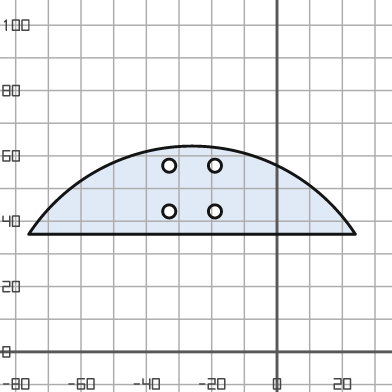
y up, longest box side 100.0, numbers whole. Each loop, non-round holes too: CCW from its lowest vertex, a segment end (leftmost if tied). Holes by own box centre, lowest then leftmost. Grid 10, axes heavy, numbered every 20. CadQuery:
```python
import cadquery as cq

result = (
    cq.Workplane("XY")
    .moveTo(-76.0, 36.0)
    .lineTo(24.0, 36.0)
    .threePointArc((-26.0, 63.0), (-76.0, 36.0))
    .close()
    .moveTo(-33.0, 43.0)
    .circle(2.0)
    .moveTo(-19.0, 43.0)
    .circle(2.0)
    .moveTo(-33.0, 57.0)
    .circle(2.0)
    .moveTo(-19.0, 57.0)
    .circle(2.0)
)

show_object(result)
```